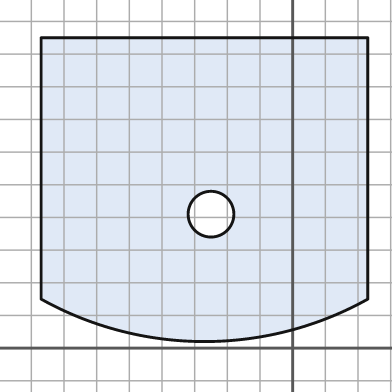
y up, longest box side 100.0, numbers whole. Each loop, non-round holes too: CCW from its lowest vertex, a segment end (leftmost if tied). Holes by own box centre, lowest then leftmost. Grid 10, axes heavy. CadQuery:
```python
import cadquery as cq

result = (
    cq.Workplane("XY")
    .moveTo(-77.0, 15.0)
    .threePointArc((-27.0, 2.0), (23.0, 15.0))
    .lineTo(23.0, 95.0)
    .lineTo(-77.0, 95.0)
    .close()
    .moveTo(-25.0, 41.0)
    .circle(7.0)
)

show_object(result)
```